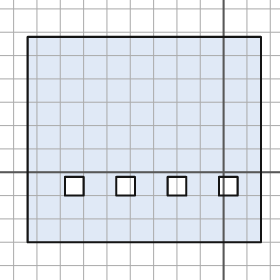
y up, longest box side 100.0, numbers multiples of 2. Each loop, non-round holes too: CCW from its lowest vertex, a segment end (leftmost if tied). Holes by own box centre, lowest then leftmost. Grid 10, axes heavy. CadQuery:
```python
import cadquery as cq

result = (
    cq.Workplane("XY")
    .moveTo(-84.0, -30.0)
    .lineTo(16.0, -30.0)
    .lineTo(16.0, 58.0)
    .lineTo(-84.0, 58.0)
    .close()
    .moveTo(-68.0, -10.0)
    .lineTo(-60.0, -10.0)
    .lineTo(-60.0, -2.0)
    .lineTo(-68.0, -2.0)
    .close()
    .moveTo(-46.0, -10.0)
    .lineTo(-38.0, -10.0)
    .lineTo(-38.0, -2.0)
    .lineTo(-46.0, -2.0)
    .close()
    .moveTo(-24.0, -10.0)
    .lineTo(-16.0, -10.0)
    .lineTo(-16.0, -2.0)
    .lineTo(-24.0, -2.0)
    .close()
    .moveTo(-2.0, -10.0)
    .lineTo(6.0, -10.0)
    .lineTo(6.0, -2.0)
    .lineTo(-2.0, -2.0)
    .close()
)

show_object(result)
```